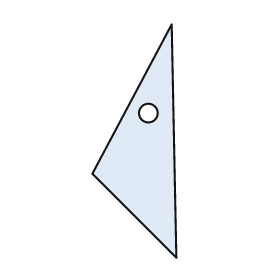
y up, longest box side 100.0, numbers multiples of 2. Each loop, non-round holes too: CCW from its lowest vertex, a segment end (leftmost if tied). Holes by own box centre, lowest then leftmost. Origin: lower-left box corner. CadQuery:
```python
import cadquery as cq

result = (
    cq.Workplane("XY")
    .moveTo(36.0, 0.0)
    .lineTo(34.0, 100.0)
    .lineTo(0.0, 36.0)
    .close()
    .moveTo(24.0, 62.0)
    .circle(4.0)
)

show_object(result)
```